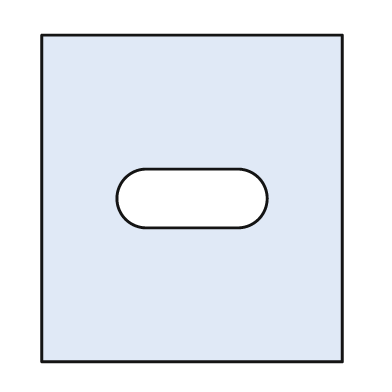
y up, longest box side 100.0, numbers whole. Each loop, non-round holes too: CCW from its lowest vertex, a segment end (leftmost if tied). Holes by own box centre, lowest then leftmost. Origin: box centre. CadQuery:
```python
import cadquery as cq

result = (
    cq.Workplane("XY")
    .moveTo(-46.0, -50.0)
    .lineTo(46.0, -50.0)
    .lineTo(46.0, 50.0)
    .lineTo(-46.0, 50.0)
    .close()
    .moveTo(-14.0, -9.0)
    .lineTo(14.0, -9.0)
    .threePointArc((23.0, 0.0), (14.0, 9.0))
    .lineTo(-14.0, 9.0)
    .threePointArc((-23.0, 0.0), (-14.0, -9.0))
    .close()
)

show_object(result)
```